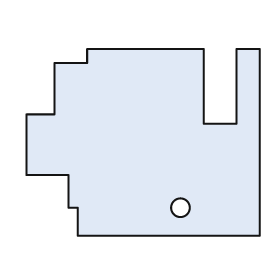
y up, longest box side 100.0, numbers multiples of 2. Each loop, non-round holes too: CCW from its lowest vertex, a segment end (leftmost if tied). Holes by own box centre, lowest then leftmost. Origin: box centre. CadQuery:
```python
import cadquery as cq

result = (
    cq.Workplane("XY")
    .moveTo(-28.0, -40.0)
    .lineTo(50.0, -40.0)
    .lineTo(50.0, 40.0)
    .lineTo(40.0, 40.0)
    .lineTo(40.0, 8.0)
    .lineTo(26.0, 8.0)
    .lineTo(26.0, 40.0)
    .lineTo(-24.0, 40.0)
    .lineTo(-24.0, 34.0)
    .lineTo(-38.0, 34.0)
    .lineTo(-38.0, 12.0)
    .lineTo(-50.0, 12.0)
    .lineTo(-50.0, -14.0)
    .lineTo(-32.0, -14.0)
    .lineTo(-32.0, -28.0)
    .lineTo(-28.0, -28.0)
    .close()
    .moveTo(16.0, -28.0)
    .circle(4.0)
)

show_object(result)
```